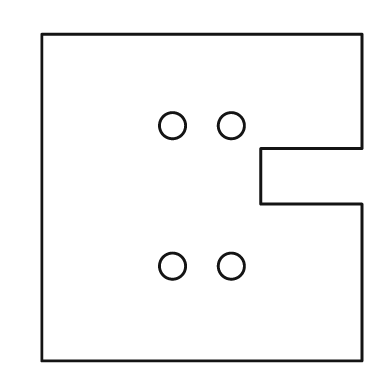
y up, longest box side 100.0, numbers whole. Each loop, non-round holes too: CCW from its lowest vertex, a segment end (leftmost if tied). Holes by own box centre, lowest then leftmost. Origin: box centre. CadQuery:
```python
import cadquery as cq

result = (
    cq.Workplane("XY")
    .moveTo(-49.0, -50.0)
    .lineTo(49.0, -50.0)
    .lineTo(49.0, -2.0)
    .lineTo(18.0, -2.0)
    .lineTo(18.0, 15.0)
    .lineTo(49.0, 15.0)
    .lineTo(49.0, 50.0)
    .lineTo(-49.0, 50.0)
    .close()
    .moveTo(-9.0, -21.0)
    .circle(4.0)
    .moveTo(9.0, -21.0)
    .circle(4.0)
    .moveTo(-9.0, 22.0)
    .circle(4.0)
    .moveTo(9.0, 22.0)
    .circle(4.0)
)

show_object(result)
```